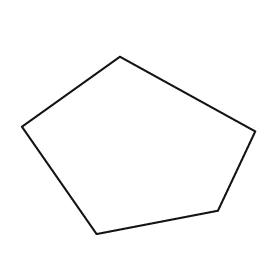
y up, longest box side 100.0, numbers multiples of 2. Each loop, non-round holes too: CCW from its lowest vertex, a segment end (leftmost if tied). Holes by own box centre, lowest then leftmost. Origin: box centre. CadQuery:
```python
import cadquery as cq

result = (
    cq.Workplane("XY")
    .moveTo(-18.0, -38.0)
    .lineTo(34.0, -28.0)
    .lineTo(50.0, 6.0)
    .lineTo(-8.0, 38.0)
    .lineTo(-50.0, 8.0)
    .close()
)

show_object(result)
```